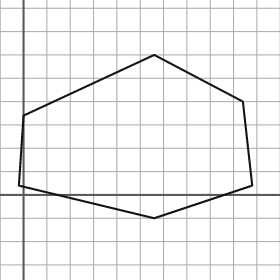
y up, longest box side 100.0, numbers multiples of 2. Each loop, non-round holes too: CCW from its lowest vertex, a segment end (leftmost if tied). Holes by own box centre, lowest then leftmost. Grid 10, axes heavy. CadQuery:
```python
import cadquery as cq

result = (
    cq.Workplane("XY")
    .moveTo(56.0, -10.0)
    .lineTo(98.0, 4.0)
    .lineTo(94.0, 40.0)
    .lineTo(56.0, 60.0)
    .lineTo(0.0, 34.0)
    .lineTo(-2.0, 4.0)
    .close()
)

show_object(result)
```